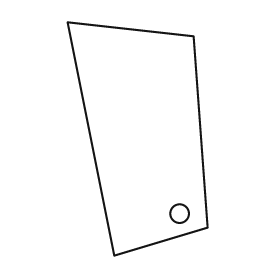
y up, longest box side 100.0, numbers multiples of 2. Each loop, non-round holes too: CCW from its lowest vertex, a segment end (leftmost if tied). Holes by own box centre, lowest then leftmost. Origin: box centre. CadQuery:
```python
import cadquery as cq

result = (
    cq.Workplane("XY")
    .moveTo(-10.0, -50.0)
    .lineTo(30.0, -38.0)
    .lineTo(24.0, 44.0)
    .lineTo(-30.0, 50.0)
    .close()
    .moveTo(18.0, -32.0)
    .circle(4.0)
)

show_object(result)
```